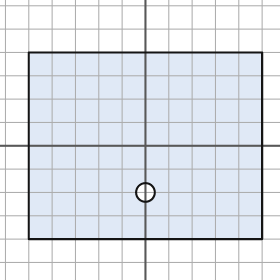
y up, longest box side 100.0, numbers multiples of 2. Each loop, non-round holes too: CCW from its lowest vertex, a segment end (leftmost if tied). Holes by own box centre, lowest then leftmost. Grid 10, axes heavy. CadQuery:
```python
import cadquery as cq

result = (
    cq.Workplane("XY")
    .moveTo(-50.0, -40.0)
    .lineTo(50.0, -40.0)
    .lineTo(50.0, 40.0)
    .lineTo(-50.0, 40.0)
    .close()
    .moveTo(0.0, -20.0)
    .circle(4.0)
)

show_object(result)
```